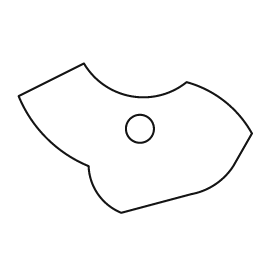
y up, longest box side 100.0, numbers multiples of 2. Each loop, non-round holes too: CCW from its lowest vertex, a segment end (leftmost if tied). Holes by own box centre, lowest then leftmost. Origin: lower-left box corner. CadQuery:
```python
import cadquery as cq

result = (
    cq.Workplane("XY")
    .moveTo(44.0, 0.0)
    .lineTo(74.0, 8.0)
    .threePointArc((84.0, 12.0), (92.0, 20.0))
    .lineTo(100.0, 34.0)
    .threePointArc((88.0, 48.0), (72.0, 56.0))
    .threePointArc((48.0, 50.0), (28.0, 64.0))
    .lineTo(0.0, 50.0)
    .threePointArc((12.0, 32.0), (30.0, 20.0))
    .threePointArc((34.0, 8.0), (44.0, 0.0))
    .close()
    .moveTo(52.0, 36.0)
    .circle(6.0)
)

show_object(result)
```